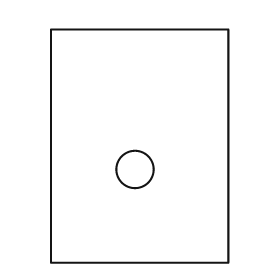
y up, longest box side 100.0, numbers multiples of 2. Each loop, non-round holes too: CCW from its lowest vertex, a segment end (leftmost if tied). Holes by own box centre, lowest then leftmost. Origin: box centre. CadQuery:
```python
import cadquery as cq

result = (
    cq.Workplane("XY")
    .moveTo(-38.0, -50.0)
    .lineTo(38.0, -50.0)
    .lineTo(38.0, 50.0)
    .lineTo(-38.0, 50.0)
    .close()
    .moveTo(-2.0, -10.0)
    .circle(8.0)
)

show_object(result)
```